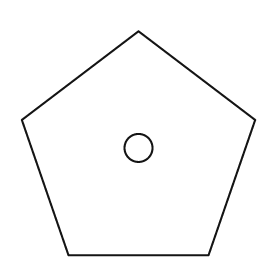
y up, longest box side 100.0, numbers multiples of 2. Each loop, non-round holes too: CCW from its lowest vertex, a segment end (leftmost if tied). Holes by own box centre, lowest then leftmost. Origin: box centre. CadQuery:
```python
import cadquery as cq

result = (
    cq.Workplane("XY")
    .moveTo(-30.0, -48.0)
    .lineTo(30.0, -48.0)
    .lineTo(50.0, 10.0)
    .lineTo(0.0, 48.0)
    .lineTo(-50.0, 10.0)
    .close()
    .moveTo(0.0, -2.0)
    .circle(6.0)
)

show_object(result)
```